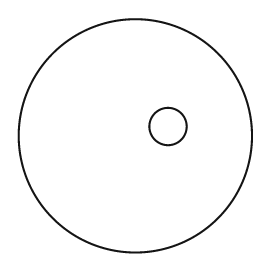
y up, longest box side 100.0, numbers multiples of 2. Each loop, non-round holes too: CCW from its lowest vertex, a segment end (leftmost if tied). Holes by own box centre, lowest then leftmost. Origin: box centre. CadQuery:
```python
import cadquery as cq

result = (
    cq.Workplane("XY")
    .moveTo(0.0, 0.0)
    .circle(50.0)
    .moveTo(14.0, 4.0)
    .circle(8.0)
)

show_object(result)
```